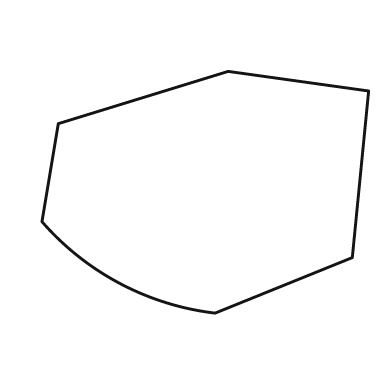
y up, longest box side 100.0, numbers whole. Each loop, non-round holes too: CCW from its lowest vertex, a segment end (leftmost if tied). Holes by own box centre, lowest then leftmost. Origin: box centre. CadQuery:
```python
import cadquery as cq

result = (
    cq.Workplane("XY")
    .moveTo(3.0, -37.0)
    .lineTo(45.0, -20.0)
    .lineTo(50.0, 31.0)
    .lineTo(7.0, 37.0)
    .lineTo(-45.0, 21.0)
    .lineTo(-50.0, -9.0)
    .threePointArc((-26.0, -28.0), (3.0, -37.0))
    .close()
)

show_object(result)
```